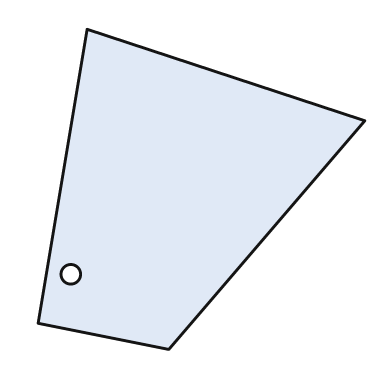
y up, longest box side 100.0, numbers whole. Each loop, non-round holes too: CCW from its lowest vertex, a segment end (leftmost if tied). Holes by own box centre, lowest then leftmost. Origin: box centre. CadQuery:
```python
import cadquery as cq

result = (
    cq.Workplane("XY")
    .moveTo(-10.0, -49.0)
    .lineTo(50.0, 21.0)
    .lineTo(-35.0, 49.0)
    .lineTo(-50.0, -41.0)
    .close()
    .moveTo(-40.0, -26.0)
    .circle(3.0)
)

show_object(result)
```